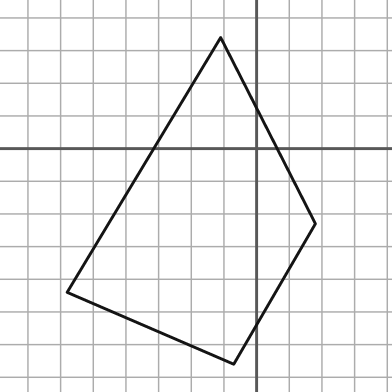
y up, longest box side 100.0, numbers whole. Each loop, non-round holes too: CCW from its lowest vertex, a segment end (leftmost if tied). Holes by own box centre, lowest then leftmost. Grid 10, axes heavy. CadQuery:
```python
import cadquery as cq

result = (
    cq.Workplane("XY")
    .moveTo(-7.0, -66.0)
    .lineTo(18.0, -23.0)
    .lineTo(-11.0, 34.0)
    .lineTo(-58.0, -44.0)
    .close()
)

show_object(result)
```